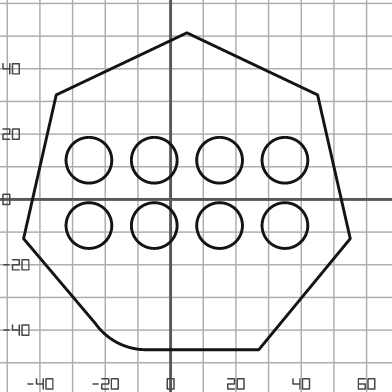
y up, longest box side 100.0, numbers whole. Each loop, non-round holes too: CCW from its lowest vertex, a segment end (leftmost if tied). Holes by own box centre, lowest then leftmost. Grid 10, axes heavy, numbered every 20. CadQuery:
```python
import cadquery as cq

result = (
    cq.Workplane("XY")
    .moveTo(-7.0, -46.0)
    .lineTo(27.0, -46.0)
    .lineTo(55.0, -12.0)
    .lineTo(45.0, 32.0)
    .lineTo(5.0, 51.0)
    .lineTo(-35.0, 32.0)
    .lineTo(-45.0, -12.0)
    .lineTo(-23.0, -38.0)
    .threePointArc((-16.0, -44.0), (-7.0, -46.0))
    .close()
    .moveTo(-25.0, -8.0)
    .circle(7.0)
    .moveTo(-5.0, -8.0)
    .circle(7.0)
    .moveTo(15.0, -8.0)
    .circle(7.0)
    .moveTo(35.0, -8.0)
    .circle(7.0)
    .moveTo(-25.0, 12.0)
    .circle(7.0)
    .moveTo(-5.0, 12.0)
    .circle(7.0)
    .moveTo(15.0, 12.0)
    .circle(7.0)
    .moveTo(35.0, 12.0)
    .circle(7.0)
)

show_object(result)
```